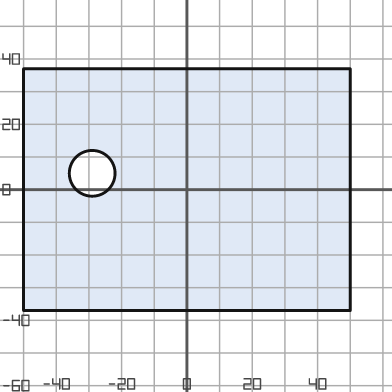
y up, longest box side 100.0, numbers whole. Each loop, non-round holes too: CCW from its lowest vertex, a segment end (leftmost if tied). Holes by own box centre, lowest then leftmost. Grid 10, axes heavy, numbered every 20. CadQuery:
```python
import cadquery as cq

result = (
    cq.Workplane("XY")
    .moveTo(-50.0, -37.0)
    .lineTo(50.0, -37.0)
    .lineTo(50.0, 37.0)
    .lineTo(-50.0, 37.0)
    .close()
    .moveTo(-29.0, 5.0)
    .circle(7.0)
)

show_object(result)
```